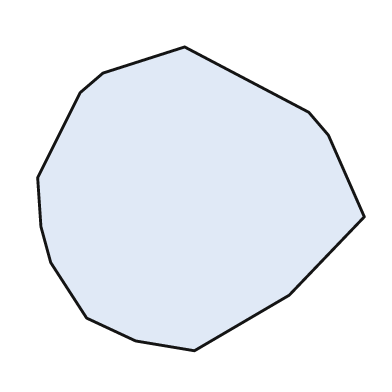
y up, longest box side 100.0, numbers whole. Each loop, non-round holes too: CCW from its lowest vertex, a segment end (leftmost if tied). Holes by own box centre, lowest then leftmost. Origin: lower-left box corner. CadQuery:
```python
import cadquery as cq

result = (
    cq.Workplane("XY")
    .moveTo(48.0, 0.0)
    .lineTo(77.0, 17.0)
    .lineTo(100.0, 41.0)
    .lineTo(89.0, 66.0)
    .lineTo(83.0, 73.0)
    .lineTo(45.0, 93.0)
    .lineTo(20.0, 85.0)
    .lineTo(13.0, 79.0)
    .lineTo(0.0, 53.0)
    .lineTo(1.0, 38.0)
    .lineTo(4.0, 27.0)
    .lineTo(15.0, 10.0)
    .lineTo(30.0, 3.0)
    .close()
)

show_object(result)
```